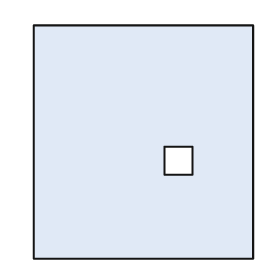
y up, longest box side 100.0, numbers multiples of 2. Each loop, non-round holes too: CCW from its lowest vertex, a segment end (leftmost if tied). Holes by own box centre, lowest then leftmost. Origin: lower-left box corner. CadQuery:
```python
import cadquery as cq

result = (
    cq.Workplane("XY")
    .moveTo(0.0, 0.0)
    .lineTo(94.0, 0.0)
    .lineTo(94.0, 100.0)
    .lineTo(0.0, 100.0)
    .close()
    .moveTo(56.0, 36.0)
    .lineTo(68.0, 36.0)
    .lineTo(68.0, 48.0)
    .lineTo(56.0, 48.0)
    .close()
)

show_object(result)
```